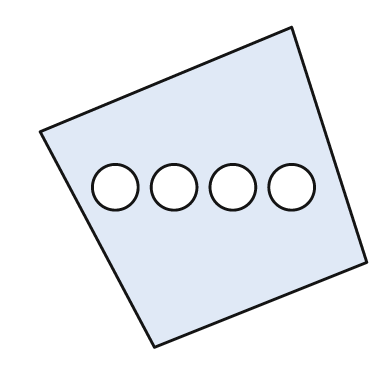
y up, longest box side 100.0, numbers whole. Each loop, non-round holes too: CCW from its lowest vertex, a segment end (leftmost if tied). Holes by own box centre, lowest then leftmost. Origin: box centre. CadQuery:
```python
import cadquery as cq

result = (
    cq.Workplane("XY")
    .moveTo(-15.0, -49.0)
    .lineTo(50.0, -23.0)
    .lineTo(27.0, 49.0)
    .lineTo(-50.0, 17.0)
    .close()
    .moveTo(-27.0, 0.0)
    .circle(7.0)
    .moveTo(-9.0, 0.0)
    .circle(7.0)
    .moveTo(9.0, 0.0)
    .circle(7.0)
    .moveTo(27.0, 0.0)
    .circle(7.0)
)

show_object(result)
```